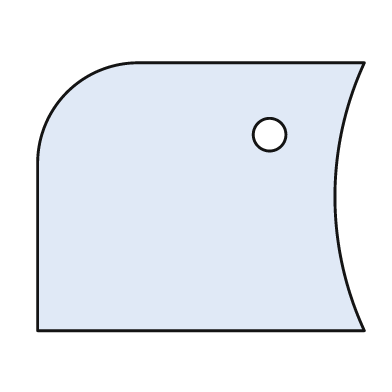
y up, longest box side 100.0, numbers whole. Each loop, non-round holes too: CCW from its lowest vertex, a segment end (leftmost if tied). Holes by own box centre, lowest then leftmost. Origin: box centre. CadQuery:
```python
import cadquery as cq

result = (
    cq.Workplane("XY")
    .moveTo(-50.0, -41.0)
    .lineTo(50.0, -41.0)
    .threePointArc((41.0, 0.0), (50.0, 41.0))
    .lineTo(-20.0, 41.0)
    .threePointArc((-41.0, 32.0), (-50.0, 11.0))
    .close()
    .moveTo(21.0, 19.0)
    .circle(5.0)
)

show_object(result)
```